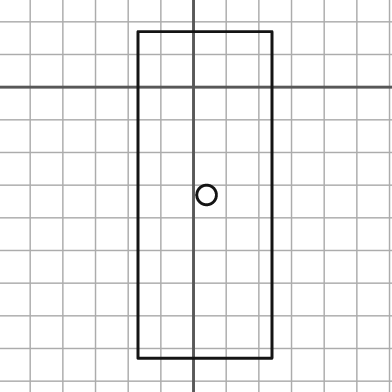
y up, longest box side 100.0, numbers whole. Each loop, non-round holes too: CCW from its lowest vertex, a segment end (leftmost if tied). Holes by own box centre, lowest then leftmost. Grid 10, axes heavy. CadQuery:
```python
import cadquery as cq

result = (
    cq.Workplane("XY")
    .moveTo(-17.0, -83.0)
    .lineTo(24.0, -83.0)
    .lineTo(24.0, 17.0)
    .lineTo(-17.0, 17.0)
    .close()
    .moveTo(4.0, -33.0)
    .circle(3.0)
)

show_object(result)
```